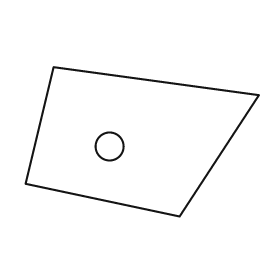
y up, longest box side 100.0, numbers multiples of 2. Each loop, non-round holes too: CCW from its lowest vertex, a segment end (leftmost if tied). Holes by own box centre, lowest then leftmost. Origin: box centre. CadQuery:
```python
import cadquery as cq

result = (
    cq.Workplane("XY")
    .moveTo(16.0, -32.0)
    .lineTo(50.0, 20.0)
    .lineTo(-38.0, 32.0)
    .lineTo(-50.0, -18.0)
    .close()
    .moveTo(-14.0, -2.0)
    .circle(6.0)
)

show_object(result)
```